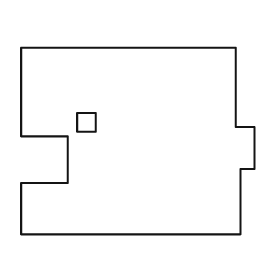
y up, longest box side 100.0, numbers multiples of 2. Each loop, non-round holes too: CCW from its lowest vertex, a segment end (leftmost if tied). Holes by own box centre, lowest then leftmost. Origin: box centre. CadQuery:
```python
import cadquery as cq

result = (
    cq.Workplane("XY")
    .moveTo(-50.0, -40.0)
    .lineTo(44.0, -40.0)
    .lineTo(44.0, -12.0)
    .lineTo(50.0, -12.0)
    .lineTo(50.0, 6.0)
    .lineTo(42.0, 6.0)
    .lineTo(42.0, 40.0)
    .lineTo(-50.0, 40.0)
    .lineTo(-50.0, 2.0)
    .lineTo(-30.0, 2.0)
    .lineTo(-30.0, -18.0)
    .lineTo(-50.0, -18.0)
    .close()
    .moveTo(-26.0, 4.0)
    .lineTo(-18.0, 4.0)
    .lineTo(-18.0, 12.0)
    .lineTo(-26.0, 12.0)
    .close()
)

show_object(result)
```